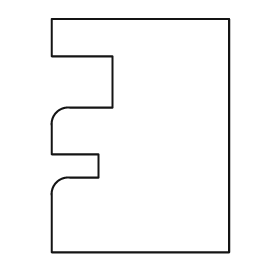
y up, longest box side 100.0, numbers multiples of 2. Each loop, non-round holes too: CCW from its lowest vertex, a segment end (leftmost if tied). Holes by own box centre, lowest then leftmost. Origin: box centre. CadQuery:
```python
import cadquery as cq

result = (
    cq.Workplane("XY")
    .moveTo(-38.0, -50.0)
    .lineTo(38.0, -50.0)
    .lineTo(38.0, 50.0)
    .lineTo(-38.0, 50.0)
    .lineTo(-38.0, 34.0)
    .lineTo(-12.0, 34.0)
    .lineTo(-12.0, 12.0)
    .lineTo(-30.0, 12.0)
    .threePointArc((-36.0, 10.0), (-38.0, 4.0))
    .lineTo(-38.0, -8.0)
    .lineTo(-18.0, -8.0)
    .lineTo(-18.0, -18.0)
    .lineTo(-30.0, -18.0)
    .threePointArc((-36.0, -20.0), (-38.0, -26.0))
    .close()
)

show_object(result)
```